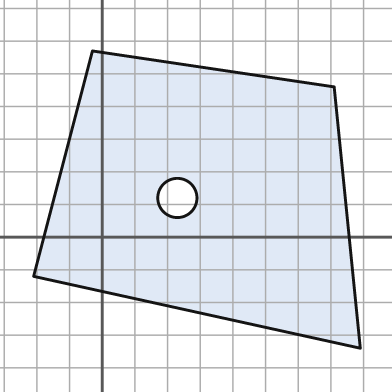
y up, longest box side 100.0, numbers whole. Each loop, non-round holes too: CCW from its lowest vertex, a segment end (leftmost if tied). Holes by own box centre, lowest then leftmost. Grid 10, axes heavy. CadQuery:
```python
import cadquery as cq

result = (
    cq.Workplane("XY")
    .moveTo(79.0, -34.0)
    .lineTo(71.0, 46.0)
    .lineTo(-3.0, 57.0)
    .lineTo(-21.0, -12.0)
    .close()
    .moveTo(23.0, 12.0)
    .circle(6.0)
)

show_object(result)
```